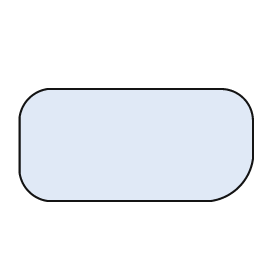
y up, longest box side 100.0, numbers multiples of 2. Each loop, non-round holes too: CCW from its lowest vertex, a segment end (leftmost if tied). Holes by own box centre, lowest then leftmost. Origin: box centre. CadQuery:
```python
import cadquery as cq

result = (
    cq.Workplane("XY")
    .moveTo(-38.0, -24.0)
    .lineTo(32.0, -24.0)
    .threePointArc((44.0, -18.0), (50.0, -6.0))
    .lineTo(50.0, 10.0)
    .threePointArc((46.0, 20.0), (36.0, 24.0))
    .lineTo(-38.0, 24.0)
    .threePointArc((-46.0, 20.0), (-50.0, 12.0))
    .lineTo(-50.0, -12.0)
    .threePointArc((-46.0, -20.0), (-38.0, -24.0))
    .close()
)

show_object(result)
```